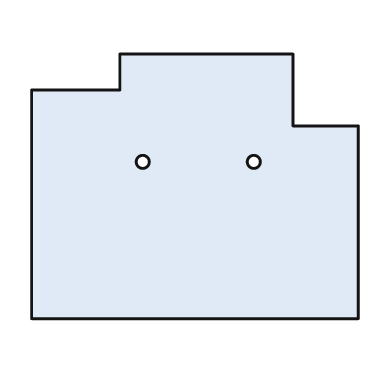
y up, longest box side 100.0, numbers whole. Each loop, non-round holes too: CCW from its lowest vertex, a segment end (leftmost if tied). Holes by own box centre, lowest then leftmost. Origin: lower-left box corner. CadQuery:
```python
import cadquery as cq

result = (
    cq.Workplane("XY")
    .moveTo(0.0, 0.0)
    .lineTo(100.0, 0.0)
    .lineTo(100.0, 59.0)
    .lineTo(80.0, 59.0)
    .lineTo(80.0, 81.0)
    .lineTo(27.0, 81.0)
    .lineTo(27.0, 70.0)
    .lineTo(0.0, 70.0)
    .close()
    .moveTo(34.0, 48.0)
    .circle(2.0)
    .moveTo(68.0, 48.0)
    .circle(2.0)
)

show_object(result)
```